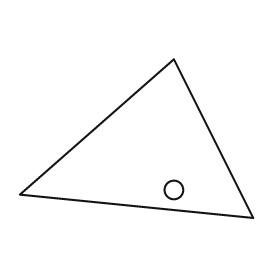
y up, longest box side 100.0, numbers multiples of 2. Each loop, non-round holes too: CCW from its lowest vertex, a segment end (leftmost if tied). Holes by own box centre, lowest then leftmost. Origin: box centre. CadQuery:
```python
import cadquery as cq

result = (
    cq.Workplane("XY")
    .moveTo(50.0, -34.0)
    .lineTo(16.0, 34.0)
    .lineTo(-50.0, -24.0)
    .close()
    .moveTo(16.0, -22.0)
    .circle(4.0)
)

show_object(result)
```